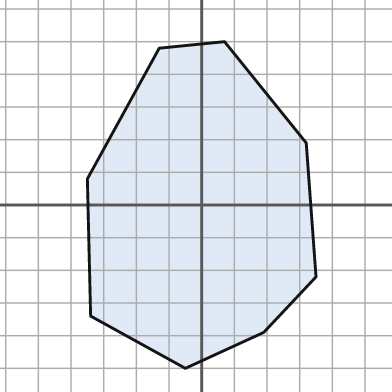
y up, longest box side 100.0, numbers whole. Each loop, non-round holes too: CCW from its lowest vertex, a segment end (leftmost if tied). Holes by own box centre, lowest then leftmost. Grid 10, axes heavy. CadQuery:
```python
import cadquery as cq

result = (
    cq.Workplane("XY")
    .moveTo(-5.0, -50.0)
    .lineTo(19.0, -39.0)
    .lineTo(35.0, -22.0)
    .lineTo(32.0, 19.0)
    .lineTo(7.0, 50.0)
    .lineTo(-13.0, 48.0)
    .lineTo(-35.0, 8.0)
    .lineTo(-34.0, -34.0)
    .close()
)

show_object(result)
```